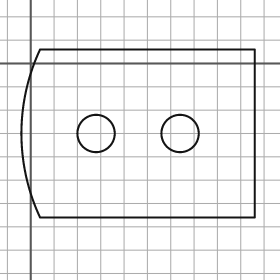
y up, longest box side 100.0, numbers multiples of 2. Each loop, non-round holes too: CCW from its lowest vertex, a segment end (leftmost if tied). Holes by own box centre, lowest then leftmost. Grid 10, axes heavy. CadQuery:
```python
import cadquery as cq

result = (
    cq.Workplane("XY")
    .moveTo(4.0, -66.0)
    .lineTo(96.0, -66.0)
    .lineTo(96.0, 6.0)
    .lineTo(4.0, 6.0)
    .threePointArc((-4.0, -30.0), (4.0, -66.0))
    .close()
    .moveTo(28.0, -30.0)
    .circle(8.0)
    .moveTo(64.0, -30.0)
    .circle(8.0)
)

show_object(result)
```